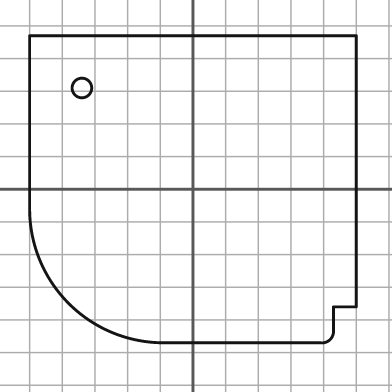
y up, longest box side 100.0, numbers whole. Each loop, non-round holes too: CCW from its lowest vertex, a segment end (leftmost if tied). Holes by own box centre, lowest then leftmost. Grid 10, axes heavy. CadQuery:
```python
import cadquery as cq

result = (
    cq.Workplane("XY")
    .moveTo(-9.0, -47.0)
    .lineTo(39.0, -47.0)
    .threePointArc((42.0, -46.0), (43.0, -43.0))
    .lineTo(43.0, -36.0)
    .lineTo(50.0, -36.0)
    .lineTo(50.0, 47.0)
    .lineTo(-50.0, 47.0)
    .lineTo(-50.0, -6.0)
    .threePointArc((-38.0, -35.0), (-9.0, -47.0))
    .close()
    .moveTo(-34.0, 31.0)
    .circle(3.0)
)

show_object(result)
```